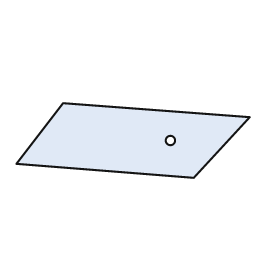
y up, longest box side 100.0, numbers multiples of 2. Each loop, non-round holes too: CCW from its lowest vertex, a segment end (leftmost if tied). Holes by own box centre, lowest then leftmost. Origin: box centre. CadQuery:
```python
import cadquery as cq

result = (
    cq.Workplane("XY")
    .moveTo(26.0, -16.0)
    .lineTo(50.0, 10.0)
    .lineTo(-30.0, 16.0)
    .lineTo(-50.0, -10.0)
    .close()
    .moveTo(16.0, 0.0)
    .circle(2.0)
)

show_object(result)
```